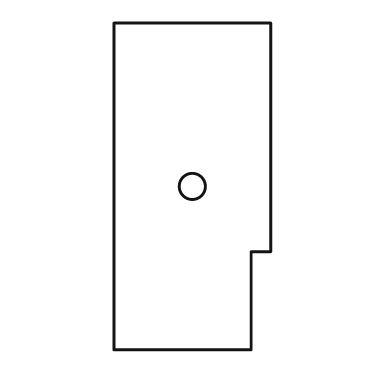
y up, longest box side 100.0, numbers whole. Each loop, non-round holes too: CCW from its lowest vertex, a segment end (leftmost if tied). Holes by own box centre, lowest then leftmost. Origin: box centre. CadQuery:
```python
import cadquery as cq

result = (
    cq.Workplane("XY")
    .moveTo(-24.0, -50.0)
    .lineTo(18.0, -50.0)
    .lineTo(18.0, -20.0)
    .lineTo(24.0, -20.0)
    .lineTo(24.0, 50.0)
    .lineTo(-24.0, 50.0)
    .close()
    .moveTo(0.0, 0.0)
    .circle(4.0)
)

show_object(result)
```